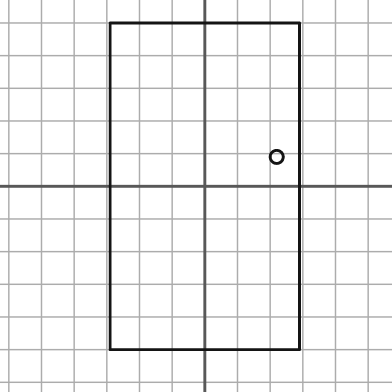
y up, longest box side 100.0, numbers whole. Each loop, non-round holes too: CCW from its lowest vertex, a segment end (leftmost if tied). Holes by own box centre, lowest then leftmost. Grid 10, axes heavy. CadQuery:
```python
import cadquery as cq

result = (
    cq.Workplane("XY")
    .moveTo(-29.0, -50.0)
    .lineTo(29.0, -50.0)
    .lineTo(29.0, 50.0)
    .lineTo(-29.0, 50.0)
    .close()
    .moveTo(22.0, 9.0)
    .circle(2.0)
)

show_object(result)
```